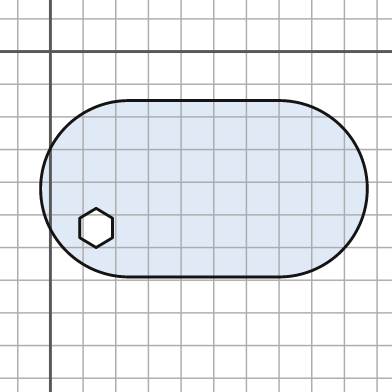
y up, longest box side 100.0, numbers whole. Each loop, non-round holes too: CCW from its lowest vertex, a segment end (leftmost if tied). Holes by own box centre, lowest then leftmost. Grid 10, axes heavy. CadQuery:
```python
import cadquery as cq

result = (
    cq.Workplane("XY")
    .moveTo(24.0, -69.0)
    .lineTo(70.0, -69.0)
    .threePointArc((97.0, -42.0), (70.0, -15.0))
    .lineTo(24.0, -15.0)
    .threePointArc((-3.0, -42.0), (24.0, -69.0))
    .close()
    .moveTo(14.0, -60.0)
    .lineTo(19.0, -57.0)
    .lineTo(19.0, -51.0)
    .lineTo(14.0, -48.0)
    .lineTo(9.0, -51.0)
    .lineTo(9.0, -57.0)
    .close()
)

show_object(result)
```